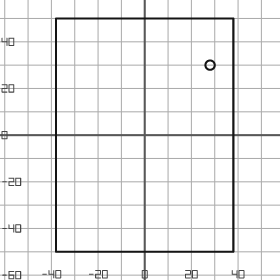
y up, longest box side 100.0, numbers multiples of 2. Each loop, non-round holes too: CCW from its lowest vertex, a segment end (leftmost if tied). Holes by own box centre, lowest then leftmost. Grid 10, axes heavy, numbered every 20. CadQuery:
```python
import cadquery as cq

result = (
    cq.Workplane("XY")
    .moveTo(-38.0, -50.0)
    .lineTo(38.0, -50.0)
    .lineTo(38.0, 50.0)
    .lineTo(-38.0, 50.0)
    .close()
    .moveTo(28.0, 30.0)
    .circle(2.0)
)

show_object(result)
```